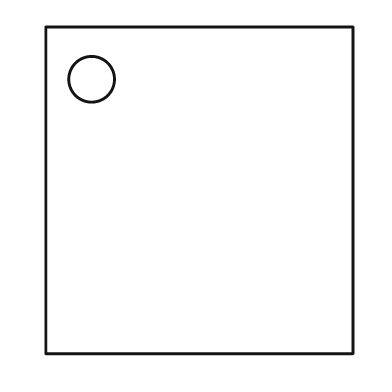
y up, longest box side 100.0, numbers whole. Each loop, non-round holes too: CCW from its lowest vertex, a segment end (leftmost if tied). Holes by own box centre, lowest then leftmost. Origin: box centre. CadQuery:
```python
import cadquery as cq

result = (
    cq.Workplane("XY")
    .moveTo(-47.0, -50.0)
    .lineTo(47.0, -50.0)
    .lineTo(47.0, 50.0)
    .lineTo(-47.0, 50.0)
    .close()
    .moveTo(-33.0, 34.0)
    .circle(7.0)
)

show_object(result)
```